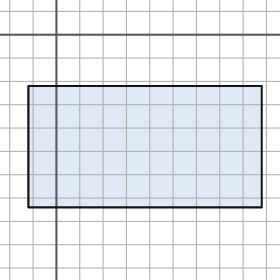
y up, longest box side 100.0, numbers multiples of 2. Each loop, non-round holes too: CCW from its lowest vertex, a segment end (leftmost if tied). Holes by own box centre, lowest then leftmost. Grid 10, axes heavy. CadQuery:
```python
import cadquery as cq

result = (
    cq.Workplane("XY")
    .moveTo(-12.0, -74.0)
    .lineTo(88.0, -74.0)
    .lineTo(88.0, -22.0)
    .lineTo(-12.0, -22.0)
    .close()
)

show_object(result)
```